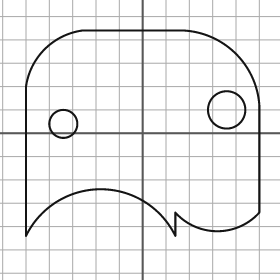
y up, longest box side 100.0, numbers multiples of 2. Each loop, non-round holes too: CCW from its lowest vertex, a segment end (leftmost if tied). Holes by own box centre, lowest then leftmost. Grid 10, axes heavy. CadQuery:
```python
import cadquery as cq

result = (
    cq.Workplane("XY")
    .moveTo(-50.0, -44.0)
    .threePointArc((-18.0, -24.0), (14.0, -44.0))
    .lineTo(14.0, -34.0)
    .threePointArc((32.0, -42.0), (50.0, -34.0))
    .lineTo(50.0, 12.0)
    .threePointArc((40.0, 34.0), (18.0, 44.0))
    .lineTo(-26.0, 44.0)
    .threePointArc((-42.0, 36.0), (-50.0, 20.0))
    .close()
    .moveTo(-34.0, 4.0)
    .circle(6.0)
    .moveTo(36.0, 10.0)
    .circle(8.0)
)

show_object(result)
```